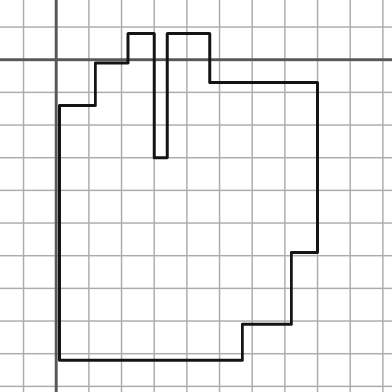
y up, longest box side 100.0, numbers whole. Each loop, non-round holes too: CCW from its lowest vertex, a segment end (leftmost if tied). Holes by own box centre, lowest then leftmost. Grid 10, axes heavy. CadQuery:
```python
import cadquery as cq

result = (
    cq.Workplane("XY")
    .moveTo(1.0, -92.0)
    .lineTo(57.0, -92.0)
    .lineTo(57.0, -81.0)
    .lineTo(72.0, -81.0)
    .lineTo(72.0, -59.0)
    .lineTo(80.0, -59.0)
    .lineTo(80.0, -7.0)
    .lineTo(47.0, -7.0)
    .lineTo(47.0, 8.0)
    .lineTo(34.0, 8.0)
    .lineTo(34.0, -30.0)
    .lineTo(30.0, -30.0)
    .lineTo(30.0, 8.0)
    .lineTo(22.0, 8.0)
    .lineTo(22.0, -1.0)
    .lineTo(12.0, -1.0)
    .lineTo(12.0, -14.0)
    .lineTo(1.0, -14.0)
    .close()
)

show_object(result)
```